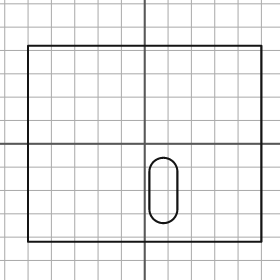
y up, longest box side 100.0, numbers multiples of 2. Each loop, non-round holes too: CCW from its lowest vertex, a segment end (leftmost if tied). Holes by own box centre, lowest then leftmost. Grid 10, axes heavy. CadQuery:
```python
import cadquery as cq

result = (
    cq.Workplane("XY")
    .moveTo(-50.0, -42.0)
    .lineTo(50.0, -42.0)
    .lineTo(50.0, 42.0)
    .lineTo(-50.0, 42.0)
    .close()
    .moveTo(2.0, -28.0)
    .threePointArc((8.0, -34.0), (14.0, -28.0))
    .lineTo(14.0, -12.0)
    .threePointArc((8.0, -6.0), (2.0, -12.0))
    .close()
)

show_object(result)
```